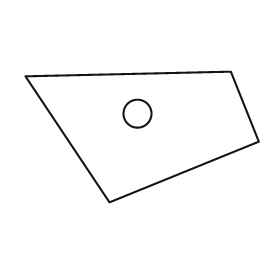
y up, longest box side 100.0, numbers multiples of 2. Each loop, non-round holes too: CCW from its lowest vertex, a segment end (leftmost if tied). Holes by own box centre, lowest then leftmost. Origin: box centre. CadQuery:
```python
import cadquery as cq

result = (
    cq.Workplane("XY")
    .moveTo(-14.0, -28.0)
    .lineTo(50.0, -2.0)
    .lineTo(38.0, 28.0)
    .lineTo(-50.0, 26.0)
    .close()
    .moveTo(-2.0, 10.0)
    .circle(6.0)
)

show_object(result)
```